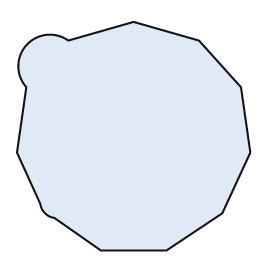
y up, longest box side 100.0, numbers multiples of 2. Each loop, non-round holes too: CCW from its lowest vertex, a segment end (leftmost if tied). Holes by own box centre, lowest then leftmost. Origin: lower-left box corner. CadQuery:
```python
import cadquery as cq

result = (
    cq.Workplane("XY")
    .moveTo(36.0, 0.0)
    .lineTo(64.0, 0.0)
    .lineTo(88.0, 16.0)
    .lineTo(100.0, 42.0)
    .lineTo(96.0, 70.0)
    .lineTo(78.0, 90.0)
    .lineTo(50.0, 98.0)
    .lineTo(22.0, 90.0)
    .threePointArc((4.0, 88.0), (4.0, 70.0))
    .lineTo(0.0, 42.0)
    .lineTo(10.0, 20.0)
    .threePointArc((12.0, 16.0), (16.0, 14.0))
    .close()
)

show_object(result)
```